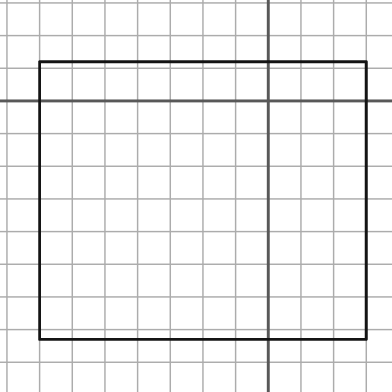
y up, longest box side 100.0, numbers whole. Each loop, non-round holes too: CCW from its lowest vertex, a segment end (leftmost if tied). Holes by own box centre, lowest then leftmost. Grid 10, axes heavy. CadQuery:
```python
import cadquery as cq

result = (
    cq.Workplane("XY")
    .moveTo(-70.0, -73.0)
    .lineTo(30.0, -73.0)
    .lineTo(30.0, 12.0)
    .lineTo(-70.0, 12.0)
    .close()
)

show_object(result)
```